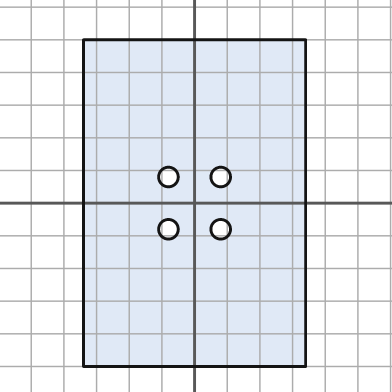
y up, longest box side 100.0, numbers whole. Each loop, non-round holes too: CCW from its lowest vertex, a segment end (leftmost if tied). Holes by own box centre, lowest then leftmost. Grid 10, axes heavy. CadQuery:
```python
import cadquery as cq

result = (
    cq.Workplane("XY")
    .moveTo(-34.0, -50.0)
    .lineTo(34.0, -50.0)
    .lineTo(34.0, 50.0)
    .lineTo(-34.0, 50.0)
    .close()
    .moveTo(-8.0, -8.0)
    .circle(3.0)
    .moveTo(8.0, -8.0)
    .circle(3.0)
    .moveTo(-8.0, 8.0)
    .circle(3.0)
    .moveTo(8.0, 8.0)
    .circle(3.0)
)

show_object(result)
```